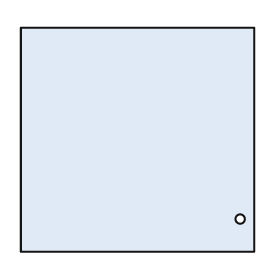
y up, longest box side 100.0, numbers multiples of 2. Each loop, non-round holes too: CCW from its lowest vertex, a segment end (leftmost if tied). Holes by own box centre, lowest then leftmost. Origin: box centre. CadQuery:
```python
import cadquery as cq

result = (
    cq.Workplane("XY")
    .moveTo(-50.0, -48.0)
    .lineTo(50.0, -48.0)
    .lineTo(50.0, 48.0)
    .lineTo(-50.0, 48.0)
    .close()
    .moveTo(44.0, -34.0)
    .circle(2.0)
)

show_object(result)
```